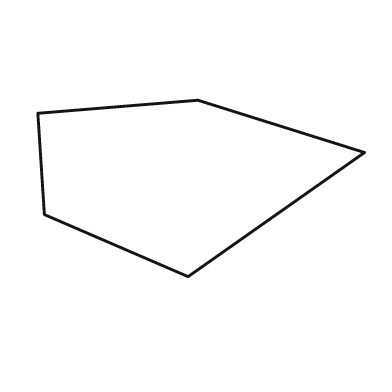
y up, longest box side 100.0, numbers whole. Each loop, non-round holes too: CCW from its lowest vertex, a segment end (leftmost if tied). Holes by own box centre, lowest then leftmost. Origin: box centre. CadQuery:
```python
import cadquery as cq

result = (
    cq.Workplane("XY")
    .moveTo(-4.0, -27.0)
    .lineTo(50.0, 11.0)
    .lineTo(-1.0, 27.0)
    .lineTo(-50.0, 23.0)
    .lineTo(-48.0, -8.0)
    .close()
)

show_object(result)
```